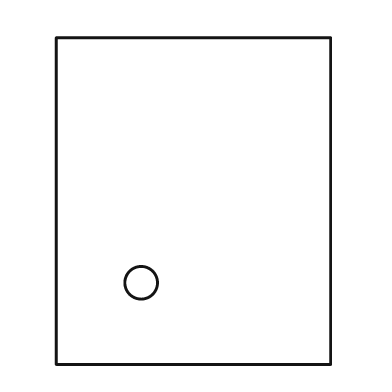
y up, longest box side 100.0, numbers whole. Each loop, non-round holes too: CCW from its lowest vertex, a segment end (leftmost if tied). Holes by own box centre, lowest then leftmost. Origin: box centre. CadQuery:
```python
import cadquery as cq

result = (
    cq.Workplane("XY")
    .moveTo(-42.0, -50.0)
    .lineTo(42.0, -50.0)
    .lineTo(42.0, 50.0)
    .lineTo(-42.0, 50.0)
    .close()
    .moveTo(-16.0, -25.0)
    .circle(5.0)
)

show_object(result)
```